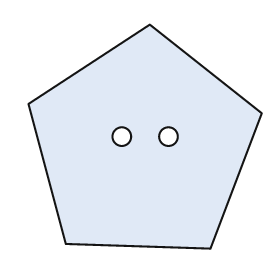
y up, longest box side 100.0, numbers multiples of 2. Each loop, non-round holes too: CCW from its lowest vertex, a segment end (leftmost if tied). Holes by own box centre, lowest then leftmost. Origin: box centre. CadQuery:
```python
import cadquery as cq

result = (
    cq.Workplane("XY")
    .moveTo(28.0, -48.0)
    .lineTo(50.0, 10.0)
    .lineTo(2.0, 48.0)
    .lineTo(-50.0, 14.0)
    .lineTo(-34.0, -46.0)
    .close()
    .moveTo(-10.0, 0.0)
    .circle(4.0)
    .moveTo(10.0, 0.0)
    .circle(4.0)
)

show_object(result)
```